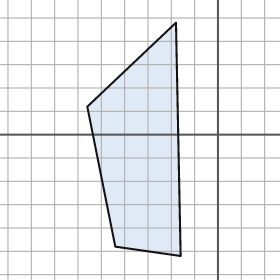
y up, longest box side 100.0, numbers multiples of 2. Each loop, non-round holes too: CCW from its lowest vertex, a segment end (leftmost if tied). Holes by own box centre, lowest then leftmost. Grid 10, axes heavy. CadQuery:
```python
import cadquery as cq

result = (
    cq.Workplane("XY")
    .moveTo(-16.0, -52.0)
    .lineTo(-18.0, 48.0)
    .lineTo(-56.0, 12.0)
    .lineTo(-44.0, -48.0)
    .close()
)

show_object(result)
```